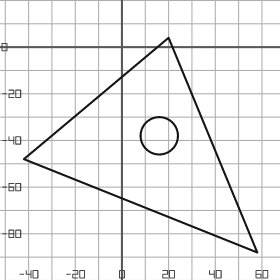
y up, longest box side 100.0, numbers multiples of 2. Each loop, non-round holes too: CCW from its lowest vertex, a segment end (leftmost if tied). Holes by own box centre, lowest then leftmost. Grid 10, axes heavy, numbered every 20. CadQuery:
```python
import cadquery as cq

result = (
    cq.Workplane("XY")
    .moveTo(58.0, -88.0)
    .lineTo(20.0, 4.0)
    .lineTo(-42.0, -48.0)
    .close()
    .moveTo(16.0, -38.0)
    .circle(8.0)
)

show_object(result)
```